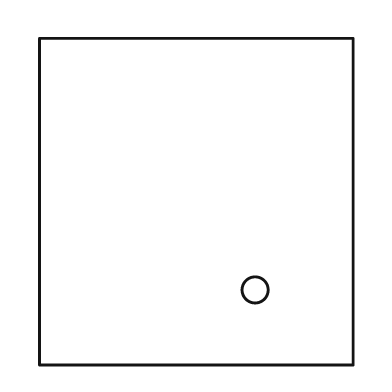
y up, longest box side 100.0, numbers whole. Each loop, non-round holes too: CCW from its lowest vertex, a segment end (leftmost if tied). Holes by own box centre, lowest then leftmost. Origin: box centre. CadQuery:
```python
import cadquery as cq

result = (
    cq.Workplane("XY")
    .moveTo(-48.0, -50.0)
    .lineTo(48.0, -50.0)
    .lineTo(48.0, 50.0)
    .lineTo(-48.0, 50.0)
    .close()
    .moveTo(18.0, -27.0)
    .circle(4.0)
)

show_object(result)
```